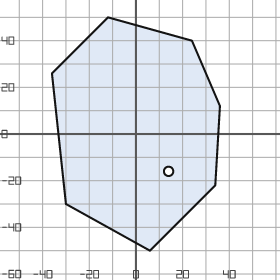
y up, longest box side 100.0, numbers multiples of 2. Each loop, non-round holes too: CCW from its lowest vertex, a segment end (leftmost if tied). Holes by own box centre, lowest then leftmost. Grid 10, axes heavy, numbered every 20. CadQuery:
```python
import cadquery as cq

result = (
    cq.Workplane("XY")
    .moveTo(6.0, -50.0)
    .lineTo(34.0, -22.0)
    .lineTo(36.0, 12.0)
    .lineTo(24.0, 40.0)
    .lineTo(-12.0, 50.0)
    .lineTo(-36.0, 26.0)
    .lineTo(-30.0, -30.0)
    .close()
    .moveTo(14.0, -16.0)
    .circle(2.0)
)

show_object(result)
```